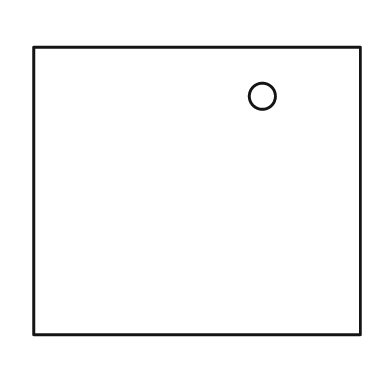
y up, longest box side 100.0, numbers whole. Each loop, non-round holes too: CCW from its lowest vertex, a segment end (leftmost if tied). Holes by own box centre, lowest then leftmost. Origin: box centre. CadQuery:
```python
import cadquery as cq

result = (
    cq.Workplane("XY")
    .moveTo(-50.0, -44.0)
    .lineTo(50.0, -44.0)
    .lineTo(50.0, 44.0)
    .lineTo(-50.0, 44.0)
    .close()
    .moveTo(20.0, 29.0)
    .circle(4.0)
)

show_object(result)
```